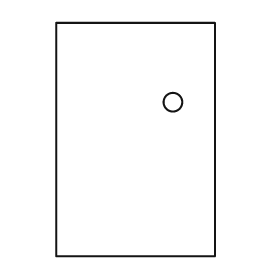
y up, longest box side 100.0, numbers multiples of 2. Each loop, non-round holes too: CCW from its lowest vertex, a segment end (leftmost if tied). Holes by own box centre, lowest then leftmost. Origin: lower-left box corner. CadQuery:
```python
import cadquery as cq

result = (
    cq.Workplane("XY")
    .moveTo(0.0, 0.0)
    .lineTo(68.0, 0.0)
    .lineTo(68.0, 100.0)
    .lineTo(0.0, 100.0)
    .close()
    .moveTo(50.0, 66.0)
    .circle(4.0)
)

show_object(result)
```